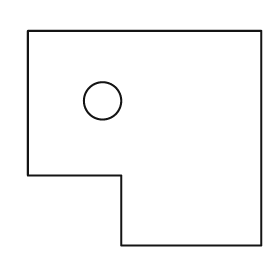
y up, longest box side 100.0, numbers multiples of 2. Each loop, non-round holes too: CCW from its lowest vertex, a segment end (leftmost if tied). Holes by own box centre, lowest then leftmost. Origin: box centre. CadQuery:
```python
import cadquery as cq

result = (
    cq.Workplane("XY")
    .moveTo(-10.0, -46.0)
    .lineTo(50.0, -46.0)
    .lineTo(50.0, 46.0)
    .lineTo(-50.0, 46.0)
    .lineTo(-50.0, -16.0)
    .lineTo(-10.0, -16.0)
    .close()
    .moveTo(-18.0, 16.0)
    .circle(8.0)
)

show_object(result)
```